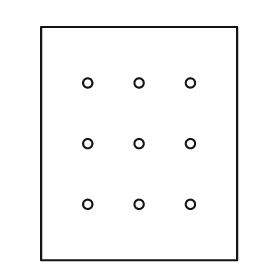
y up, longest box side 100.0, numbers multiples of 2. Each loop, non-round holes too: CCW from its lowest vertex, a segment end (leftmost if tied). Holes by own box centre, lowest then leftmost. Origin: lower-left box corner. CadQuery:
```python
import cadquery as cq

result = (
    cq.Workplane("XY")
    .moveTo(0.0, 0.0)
    .lineTo(84.0, 0.0)
    .lineTo(84.0, 100.0)
    .lineTo(0.0, 100.0)
    .close()
    .moveTo(20.0, 24.0)
    .circle(2.0)
    .moveTo(42.0, 24.0)
    .circle(2.0)
    .moveTo(64.0, 24.0)
    .circle(2.0)
    .moveTo(20.0, 50.0)
    .circle(2.0)
    .moveTo(42.0, 50.0)
    .circle(2.0)
    .moveTo(64.0, 50.0)
    .circle(2.0)
    .moveTo(20.0, 76.0)
    .circle(2.0)
    .moveTo(42.0, 76.0)
    .circle(2.0)
    .moveTo(64.0, 76.0)
    .circle(2.0)
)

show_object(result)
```